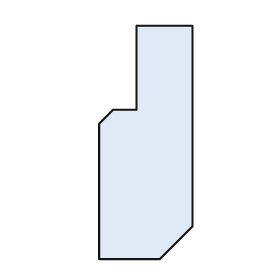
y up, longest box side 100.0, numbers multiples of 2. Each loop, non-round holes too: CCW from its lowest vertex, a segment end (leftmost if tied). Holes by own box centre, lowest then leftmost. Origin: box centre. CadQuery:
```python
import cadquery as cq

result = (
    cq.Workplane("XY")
    .moveTo(-20.0, -50.0)
    .lineTo(6.0, -50.0)
    .lineTo(20.0, -36.0)
    .lineTo(20.0, 50.0)
    .lineTo(-4.0, 50.0)
    .lineTo(-4.0, 14.0)
    .lineTo(-14.0, 14.0)
    .lineTo(-20.0, 8.0)
    .close()
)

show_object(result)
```